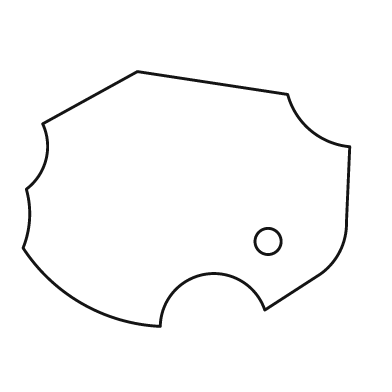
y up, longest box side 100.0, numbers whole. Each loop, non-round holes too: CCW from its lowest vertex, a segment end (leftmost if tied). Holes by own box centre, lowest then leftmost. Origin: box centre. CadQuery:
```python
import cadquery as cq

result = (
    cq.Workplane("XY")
    .moveTo(-8.0, -39.0)
    .threePointArc((6.0, -23.0), (24.0, -34.0))
    .lineTo(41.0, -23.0)
    .threePointArc((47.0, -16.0), (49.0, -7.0))
    .lineTo(50.0, 16.0)
    .threePointArc((38.0, 21.0), (31.0, 32.0))
    .lineTo(-15.0, 39.0)
    .lineTo(-44.0, 23.0)
    .threePointArc((-43.0, 12.0), (-49.0, 3.0))
    .threePointArc((-48.0, -6.0), (-50.0, -15.0))
    .threePointArc((-32.0, -32.0), (-8.0, -39.0))
    .close()
    .moveTo(25.0, -13.0)
    .circle(4.0)
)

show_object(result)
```